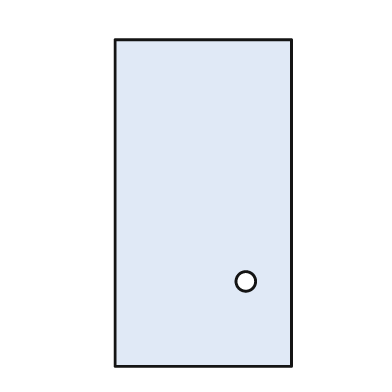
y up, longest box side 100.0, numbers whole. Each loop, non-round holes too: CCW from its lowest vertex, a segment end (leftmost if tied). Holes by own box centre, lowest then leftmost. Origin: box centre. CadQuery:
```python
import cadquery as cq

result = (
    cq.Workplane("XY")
    .moveTo(-27.0, -50.0)
    .lineTo(27.0, -50.0)
    .lineTo(27.0, 50.0)
    .lineTo(-27.0, 50.0)
    .close()
    .moveTo(13.0, -24.0)
    .circle(3.0)
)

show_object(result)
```